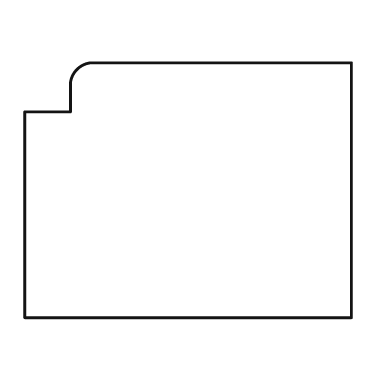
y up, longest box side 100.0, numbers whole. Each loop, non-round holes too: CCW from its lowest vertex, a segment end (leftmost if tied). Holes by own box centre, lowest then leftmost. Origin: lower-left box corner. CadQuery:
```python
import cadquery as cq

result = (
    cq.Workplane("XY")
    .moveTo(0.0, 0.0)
    .lineTo(100.0, 0.0)
    .lineTo(100.0, 78.0)
    .lineTo(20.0, 78.0)
    .threePointArc((16.0, 76.0), (14.0, 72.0))
    .lineTo(14.0, 63.0)
    .lineTo(0.0, 63.0)
    .close()
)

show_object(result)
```